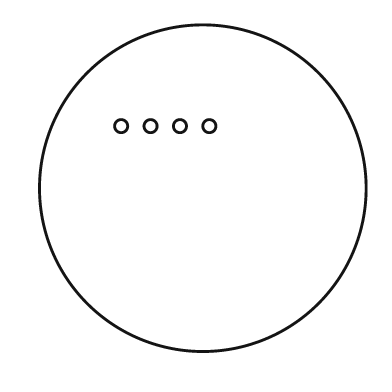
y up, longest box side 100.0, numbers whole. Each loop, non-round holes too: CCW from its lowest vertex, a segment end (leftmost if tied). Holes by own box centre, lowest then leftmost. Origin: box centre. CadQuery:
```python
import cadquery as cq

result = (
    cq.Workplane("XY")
    .moveTo(0.0, 0.0)
    .circle(50.0)
    .moveTo(-25.0, 19.0)
    .circle(2.0)
    .moveTo(-16.0, 19.0)
    .circle(2.0)
    .moveTo(-7.0, 19.0)
    .circle(2.0)
    .moveTo(2.0, 19.0)
    .circle(2.0)
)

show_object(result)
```